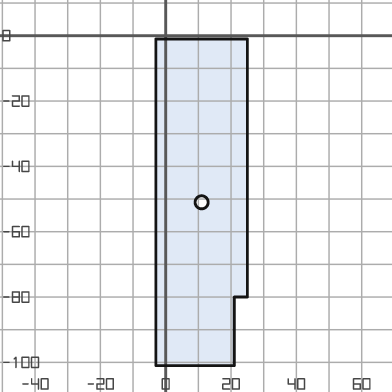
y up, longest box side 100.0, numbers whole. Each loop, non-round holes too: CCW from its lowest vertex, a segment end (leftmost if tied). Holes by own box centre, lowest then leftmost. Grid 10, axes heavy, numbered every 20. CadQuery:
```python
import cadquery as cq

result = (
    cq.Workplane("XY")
    .moveTo(-3.0, -101.0)
    .lineTo(21.0, -101.0)
    .lineTo(21.0, -80.0)
    .lineTo(25.0, -80.0)
    .lineTo(25.0, -1.0)
    .lineTo(-3.0, -1.0)
    .close()
    .moveTo(11.0, -51.0)
    .circle(2.0)
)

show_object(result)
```